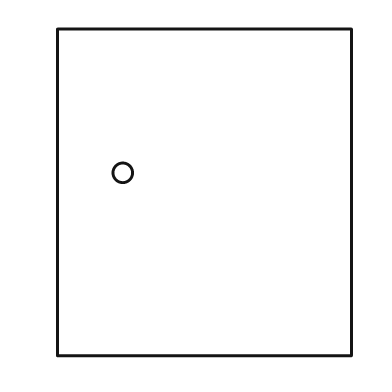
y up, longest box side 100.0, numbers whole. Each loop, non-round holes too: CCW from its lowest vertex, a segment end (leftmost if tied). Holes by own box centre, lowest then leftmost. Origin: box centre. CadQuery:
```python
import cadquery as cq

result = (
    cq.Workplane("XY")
    .moveTo(-45.0, -50.0)
    .lineTo(45.0, -50.0)
    .lineTo(45.0, 50.0)
    .lineTo(-45.0, 50.0)
    .close()
    .moveTo(-25.0, 6.0)
    .circle(3.0)
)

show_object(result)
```